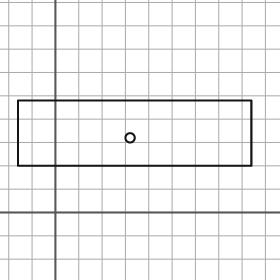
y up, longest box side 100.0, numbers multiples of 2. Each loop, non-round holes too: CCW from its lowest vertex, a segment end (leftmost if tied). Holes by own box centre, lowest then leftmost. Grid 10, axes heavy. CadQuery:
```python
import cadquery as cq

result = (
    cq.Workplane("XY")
    .moveTo(-16.0, 20.0)
    .lineTo(84.0, 20.0)
    .lineTo(84.0, 48.0)
    .lineTo(-16.0, 48.0)
    .close()
    .moveTo(32.0, 32.0)
    .circle(2.0)
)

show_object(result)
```